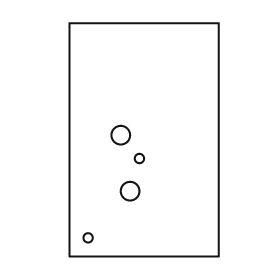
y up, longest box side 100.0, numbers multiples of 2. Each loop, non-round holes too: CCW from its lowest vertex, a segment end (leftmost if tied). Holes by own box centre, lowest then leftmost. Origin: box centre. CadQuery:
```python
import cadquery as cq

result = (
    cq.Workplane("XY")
    .moveTo(-32.0, -50.0)
    .lineTo(32.0, -50.0)
    .lineTo(32.0, 50.0)
    .lineTo(-32.0, 50.0)
    .close()
    .moveTo(-24.0, -42.0)
    .circle(2.0)
    .moveTo(-6.0, -22.0)
    .circle(4.0)
    .moveTo(-2.0, -8.0)
    .circle(2.0)
    .moveTo(-10.0, 2.0)
    .circle(4.0)
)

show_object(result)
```